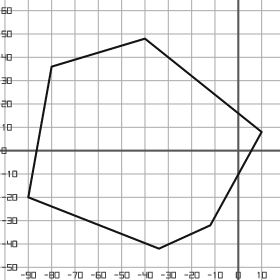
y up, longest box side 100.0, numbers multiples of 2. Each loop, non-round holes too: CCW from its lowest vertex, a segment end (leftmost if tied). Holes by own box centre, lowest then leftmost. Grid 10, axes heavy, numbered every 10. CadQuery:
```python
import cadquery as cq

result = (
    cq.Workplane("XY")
    .moveTo(-34.0, -42.0)
    .lineTo(-12.0, -32.0)
    .lineTo(10.0, 8.0)
    .lineTo(-40.0, 48.0)
    .lineTo(-80.0, 36.0)
    .lineTo(-90.0, -20.0)
    .close()
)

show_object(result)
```